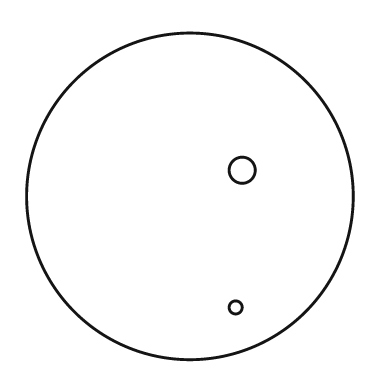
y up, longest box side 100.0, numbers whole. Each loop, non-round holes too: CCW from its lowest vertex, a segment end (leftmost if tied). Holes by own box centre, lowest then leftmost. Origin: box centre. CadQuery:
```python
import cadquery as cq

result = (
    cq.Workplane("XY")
    .moveTo(0.0, 0.0)
    .circle(50.0)
    .moveTo(14.0, -34.0)
    .circle(2.0)
    .moveTo(16.0, 8.0)
    .circle(4.0)
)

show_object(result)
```